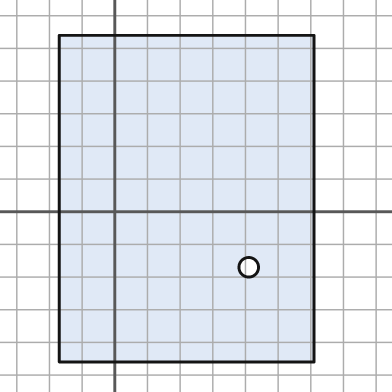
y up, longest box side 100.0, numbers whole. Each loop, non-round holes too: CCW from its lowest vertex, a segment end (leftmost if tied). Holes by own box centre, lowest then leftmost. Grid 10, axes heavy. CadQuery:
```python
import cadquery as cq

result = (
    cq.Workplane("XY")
    .moveTo(-17.0, -46.0)
    .lineTo(61.0, -46.0)
    .lineTo(61.0, 54.0)
    .lineTo(-17.0, 54.0)
    .close()
    .moveTo(41.0, -17.0)
    .circle(3.0)
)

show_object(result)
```